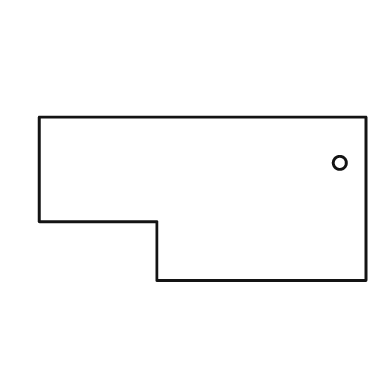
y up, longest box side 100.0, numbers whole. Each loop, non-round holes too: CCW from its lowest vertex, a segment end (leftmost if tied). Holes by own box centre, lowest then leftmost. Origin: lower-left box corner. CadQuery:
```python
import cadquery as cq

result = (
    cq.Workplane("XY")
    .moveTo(36.0, 0.0)
    .lineTo(100.0, 0.0)
    .lineTo(100.0, 50.0)
    .lineTo(0.0, 50.0)
    .lineTo(0.0, 18.0)
    .lineTo(36.0, 18.0)
    .close()
    .moveTo(92.0, 36.0)
    .circle(2.0)
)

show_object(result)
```